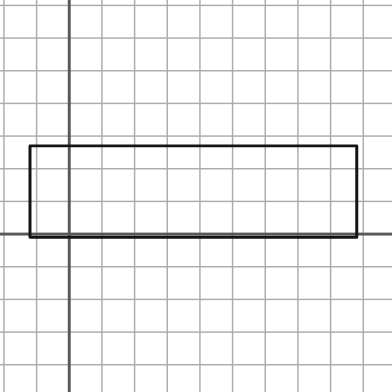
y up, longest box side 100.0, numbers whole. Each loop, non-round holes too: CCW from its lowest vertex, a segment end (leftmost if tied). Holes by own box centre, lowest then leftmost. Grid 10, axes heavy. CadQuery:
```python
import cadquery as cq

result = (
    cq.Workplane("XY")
    .moveTo(-12.0, -1.0)
    .lineTo(88.0, -1.0)
    .lineTo(88.0, 27.0)
    .lineTo(-12.0, 27.0)
    .close()
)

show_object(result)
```